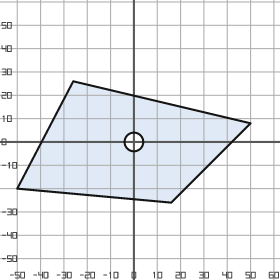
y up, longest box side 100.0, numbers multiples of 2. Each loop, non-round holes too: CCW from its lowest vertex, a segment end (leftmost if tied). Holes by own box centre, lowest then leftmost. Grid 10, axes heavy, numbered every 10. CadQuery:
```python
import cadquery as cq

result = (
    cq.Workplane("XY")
    .moveTo(16.0, -26.0)
    .lineTo(50.0, 8.0)
    .lineTo(-26.0, 26.0)
    .lineTo(-50.0, -20.0)
    .close()
    .moveTo(0.0, 0.0)
    .circle(4.0)
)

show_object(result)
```